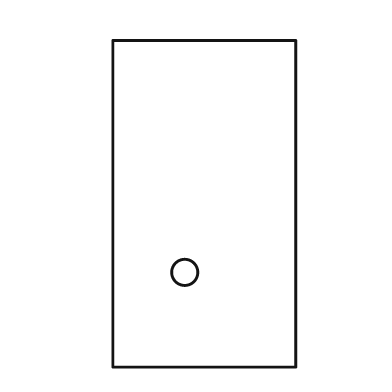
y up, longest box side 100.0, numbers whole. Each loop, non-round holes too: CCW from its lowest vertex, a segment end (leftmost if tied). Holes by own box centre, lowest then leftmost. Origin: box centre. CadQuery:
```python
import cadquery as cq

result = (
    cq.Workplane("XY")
    .moveTo(-28.0, -50.0)
    .lineTo(28.0, -50.0)
    .lineTo(28.0, 50.0)
    .lineTo(-28.0, 50.0)
    .close()
    .moveTo(-6.0, -21.0)
    .circle(4.0)
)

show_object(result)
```